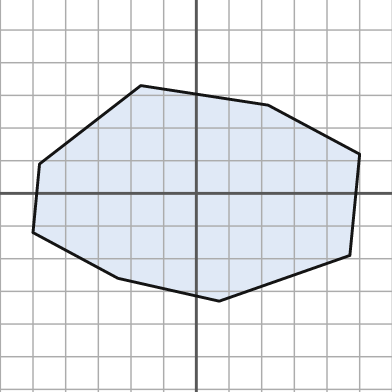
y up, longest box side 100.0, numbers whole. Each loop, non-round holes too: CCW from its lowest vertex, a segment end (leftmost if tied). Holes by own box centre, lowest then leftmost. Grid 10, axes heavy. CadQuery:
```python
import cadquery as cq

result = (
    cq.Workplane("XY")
    .moveTo(7.0, -33.0)
    .lineTo(47.0, -19.0)
    .lineTo(50.0, 12.0)
    .lineTo(22.0, 27.0)
    .lineTo(-17.0, 33.0)
    .lineTo(-48.0, 9.0)
    .lineTo(-50.0, -12.0)
    .lineTo(-24.0, -26.0)
    .close()
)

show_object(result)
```